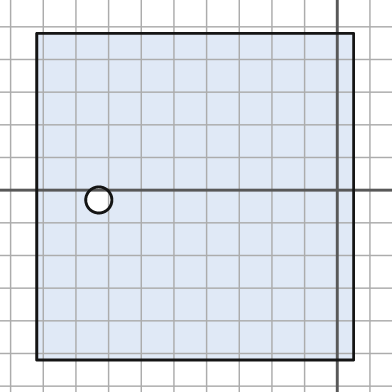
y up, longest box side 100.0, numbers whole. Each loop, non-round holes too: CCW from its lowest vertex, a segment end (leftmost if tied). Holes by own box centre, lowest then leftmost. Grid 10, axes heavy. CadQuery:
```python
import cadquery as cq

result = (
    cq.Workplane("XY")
    .moveTo(-92.0, -52.0)
    .lineTo(5.0, -52.0)
    .lineTo(5.0, 48.0)
    .lineTo(-92.0, 48.0)
    .close()
    .moveTo(-73.0, -3.0)
    .circle(4.0)
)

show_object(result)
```